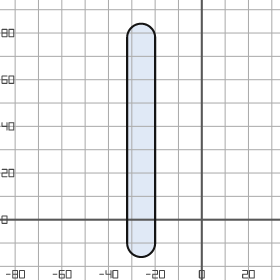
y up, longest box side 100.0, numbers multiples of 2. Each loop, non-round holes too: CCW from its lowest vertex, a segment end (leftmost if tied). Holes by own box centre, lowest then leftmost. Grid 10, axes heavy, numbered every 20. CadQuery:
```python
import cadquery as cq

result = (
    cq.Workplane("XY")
    .moveTo(-32.0, -10.0)
    .threePointArc((-26.0, -16.0), (-20.0, -10.0))
    .lineTo(-20.0, 78.0)
    .threePointArc((-26.0, 84.0), (-32.0, 78.0))
    .close()
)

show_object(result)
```